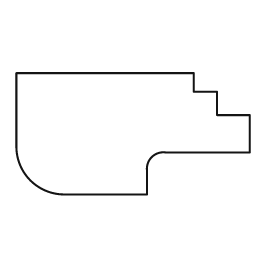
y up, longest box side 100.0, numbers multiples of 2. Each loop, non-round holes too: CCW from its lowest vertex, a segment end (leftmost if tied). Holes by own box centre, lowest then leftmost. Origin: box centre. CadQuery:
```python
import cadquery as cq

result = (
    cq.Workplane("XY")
    .moveTo(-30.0, -26.0)
    .lineTo(6.0, -26.0)
    .lineTo(6.0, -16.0)
    .threePointArc((8.0, -10.0), (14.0, -8.0))
    .lineTo(50.0, -8.0)
    .lineTo(50.0, 8.0)
    .lineTo(36.0, 8.0)
    .lineTo(36.0, 18.0)
    .lineTo(26.0, 18.0)
    .lineTo(26.0, 26.0)
    .lineTo(-50.0, 26.0)
    .lineTo(-50.0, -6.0)
    .threePointArc((-44.0, -20.0), (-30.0, -26.0))
    .close()
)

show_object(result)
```